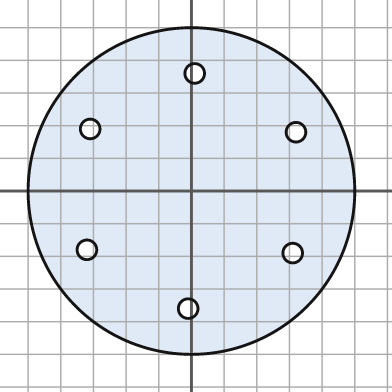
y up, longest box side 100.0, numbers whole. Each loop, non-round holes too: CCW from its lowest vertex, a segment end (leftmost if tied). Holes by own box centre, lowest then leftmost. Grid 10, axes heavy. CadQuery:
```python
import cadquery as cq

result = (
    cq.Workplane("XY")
    .moveTo(0.0, 0.0)
    .circle(50.0)
    .moveTo(-1.0, -36.0)
    .circle(3.0)
    .moveTo(31.0, -19.0)
    .circle(3.0)
    .moveTo(-32.0, -18.0)
    .circle(3.0)
    .moveTo(32.0, 18.0)
    .circle(3.0)
    .moveTo(-31.0, 19.0)
    .circle(3.0)
    .moveTo(1.0, 36.0)
    .circle(3.0)
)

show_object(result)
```